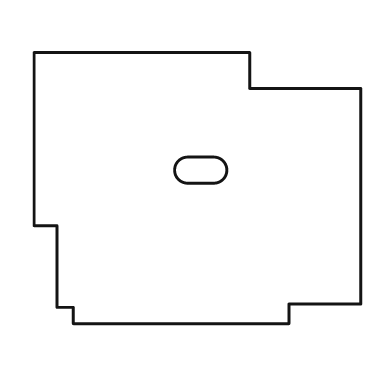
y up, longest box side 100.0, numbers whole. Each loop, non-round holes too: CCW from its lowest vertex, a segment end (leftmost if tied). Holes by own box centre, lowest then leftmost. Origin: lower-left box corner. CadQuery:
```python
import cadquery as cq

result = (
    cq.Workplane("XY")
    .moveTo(12.0, 0.0)
    .lineTo(78.0, 0.0)
    .lineTo(78.0, 6.0)
    .lineTo(100.0, 6.0)
    .lineTo(100.0, 72.0)
    .lineTo(66.0, 72.0)
    .lineTo(66.0, 83.0)
    .lineTo(0.0, 83.0)
    .lineTo(0.0, 30.0)
    .lineTo(7.0, 30.0)
    .lineTo(7.0, 5.0)
    .lineTo(12.0, 5.0)
    .close()
    .moveTo(47.0, 43.0)
    .lineTo(55.0, 43.0)
    .threePointArc((59.0, 47.0), (55.0, 51.0))
    .lineTo(47.0, 51.0)
    .threePointArc((43.0, 47.0), (47.0, 43.0))
    .close()
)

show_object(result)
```